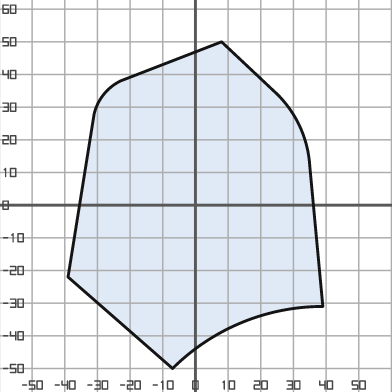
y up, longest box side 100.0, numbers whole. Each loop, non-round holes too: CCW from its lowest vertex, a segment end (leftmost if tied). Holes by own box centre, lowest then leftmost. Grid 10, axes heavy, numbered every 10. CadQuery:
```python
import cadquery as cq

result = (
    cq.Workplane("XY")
    .moveTo(-7.0, -50.0)
    .threePointArc((14.0, -36.0), (39.0, -31.0))
    .lineTo(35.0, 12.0)
    .threePointArc((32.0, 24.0), (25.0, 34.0))
    .lineTo(8.0, 50.0)
    .lineTo(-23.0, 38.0)
    .threePointArc((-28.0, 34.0), (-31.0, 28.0))
    .lineTo(-39.0, -22.0)
    .close()
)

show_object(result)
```